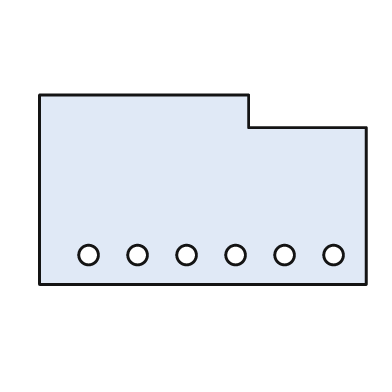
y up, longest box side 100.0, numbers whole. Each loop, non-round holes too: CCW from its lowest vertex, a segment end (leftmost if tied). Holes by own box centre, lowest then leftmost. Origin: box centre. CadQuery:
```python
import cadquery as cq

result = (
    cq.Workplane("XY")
    .moveTo(-50.0, -29.0)
    .lineTo(50.0, -29.0)
    .lineTo(50.0, 19.0)
    .lineTo(14.0, 19.0)
    .lineTo(14.0, 29.0)
    .lineTo(-50.0, 29.0)
    .close()
    .moveTo(-35.0, -20.0)
    .circle(3.0)
    .moveTo(-20.0, -20.0)
    .circle(3.0)
    .moveTo(-5.0, -20.0)
    .circle(3.0)
    .moveTo(10.0, -20.0)
    .circle(3.0)
    .moveTo(25.0, -20.0)
    .circle(3.0)
    .moveTo(40.0, -20.0)
    .circle(3.0)
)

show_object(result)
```